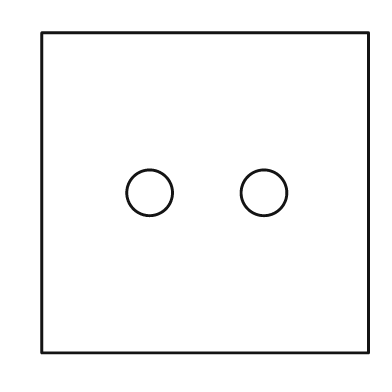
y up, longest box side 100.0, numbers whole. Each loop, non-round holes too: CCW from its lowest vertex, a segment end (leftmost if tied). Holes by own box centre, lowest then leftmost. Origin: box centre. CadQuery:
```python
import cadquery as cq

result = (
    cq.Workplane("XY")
    .moveTo(-50.0, -49.0)
    .lineTo(50.0, -49.0)
    .lineTo(50.0, 49.0)
    .lineTo(-50.0, 49.0)
    .close()
    .moveTo(-17.0, 0.0)
    .circle(7.0)
    .moveTo(18.0, 0.0)
    .circle(7.0)
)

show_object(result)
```